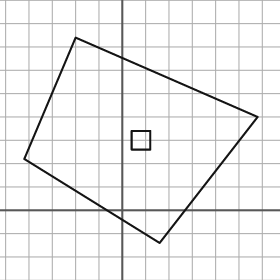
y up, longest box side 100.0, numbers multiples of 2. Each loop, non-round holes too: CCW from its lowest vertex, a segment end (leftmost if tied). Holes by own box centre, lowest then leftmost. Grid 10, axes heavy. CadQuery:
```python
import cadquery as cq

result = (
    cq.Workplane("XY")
    .moveTo(16.0, -14.0)
    .lineTo(58.0, 40.0)
    .lineTo(-20.0, 74.0)
    .lineTo(-42.0, 22.0)
    .close()
    .moveTo(4.0, 26.0)
    .lineTo(12.0, 26.0)
    .lineTo(12.0, 34.0)
    .lineTo(4.0, 34.0)
    .close()
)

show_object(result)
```